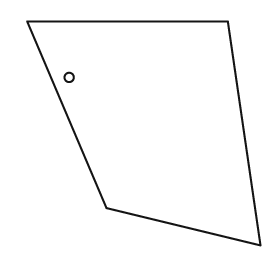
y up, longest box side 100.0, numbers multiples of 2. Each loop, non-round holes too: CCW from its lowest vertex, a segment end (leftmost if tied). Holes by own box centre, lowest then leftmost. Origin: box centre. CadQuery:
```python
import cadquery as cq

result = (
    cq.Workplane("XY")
    .moveTo(50.0, -48.0)
    .lineTo(36.0, 48.0)
    .lineTo(-50.0, 48.0)
    .lineTo(-16.0, -32.0)
    .close()
    .moveTo(-32.0, 24.0)
    .circle(2.0)
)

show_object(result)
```